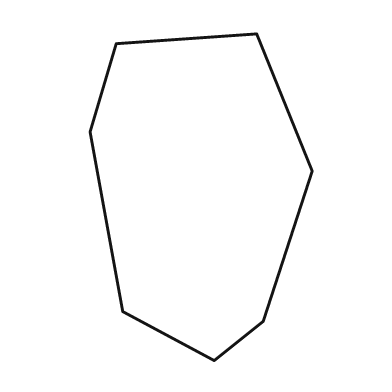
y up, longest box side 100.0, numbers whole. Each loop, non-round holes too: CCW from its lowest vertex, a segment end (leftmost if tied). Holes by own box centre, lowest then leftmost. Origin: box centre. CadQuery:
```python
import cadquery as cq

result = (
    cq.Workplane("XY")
    .moveTo(4.0, -50.0)
    .lineTo(19.0, -38.0)
    .lineTo(34.0, 8.0)
    .lineTo(17.0, 50.0)
    .lineTo(-26.0, 47.0)
    .lineTo(-34.0, 20.0)
    .lineTo(-24.0, -35.0)
    .close()
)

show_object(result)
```